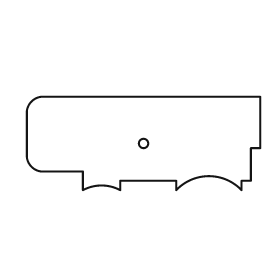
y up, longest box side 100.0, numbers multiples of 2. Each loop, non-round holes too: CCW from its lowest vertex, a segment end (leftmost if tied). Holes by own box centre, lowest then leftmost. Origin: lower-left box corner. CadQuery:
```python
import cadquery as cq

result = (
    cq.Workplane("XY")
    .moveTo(24.0, 0.0)
    .threePointArc((32.0, 2.0), (40.0, 0.0))
    .lineTo(40.0, 4.0)
    .lineTo(64.0, 4.0)
    .lineTo(64.0, 0.0)
    .threePointArc((78.0, 6.0), (92.0, 0.0))
    .lineTo(92.0, 4.0)
    .lineTo(96.0, 4.0)
    .lineTo(96.0, 18.0)
    .lineTo(100.0, 18.0)
    .lineTo(100.0, 40.0)
    .lineTo(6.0, 40.0)
    .threePointArc((2.0, 38.0), (0.0, 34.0))
    .lineTo(0.0, 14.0)
    .threePointArc((2.0, 10.0), (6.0, 8.0))
    .lineTo(24.0, 8.0)
    .close()
    .moveTo(50.0, 20.0)
    .circle(2.0)
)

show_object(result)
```